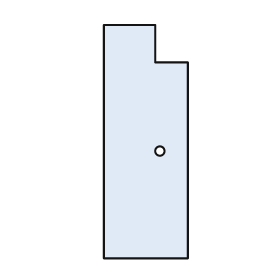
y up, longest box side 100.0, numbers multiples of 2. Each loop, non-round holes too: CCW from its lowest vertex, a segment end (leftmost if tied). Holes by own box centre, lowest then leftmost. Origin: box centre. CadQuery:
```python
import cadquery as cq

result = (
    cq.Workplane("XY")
    .moveTo(-18.0, -50.0)
    .lineTo(18.0, -50.0)
    .lineTo(18.0, 34.0)
    .lineTo(4.0, 34.0)
    .lineTo(4.0, 50.0)
    .lineTo(-18.0, 50.0)
    .close()
    .moveTo(6.0, -4.0)
    .circle(2.0)
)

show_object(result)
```